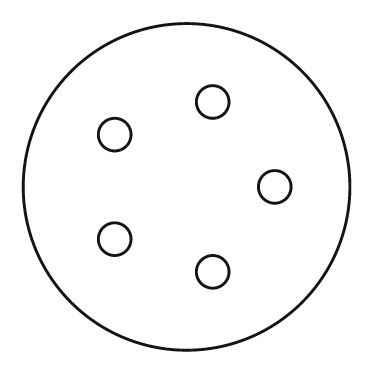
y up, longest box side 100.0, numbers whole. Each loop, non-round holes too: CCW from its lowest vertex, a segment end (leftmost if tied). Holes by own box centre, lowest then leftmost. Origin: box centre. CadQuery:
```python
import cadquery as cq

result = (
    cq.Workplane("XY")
    .moveTo(0.0, 0.0)
    .circle(50.0)
    .moveTo(8.0, -26.0)
    .circle(5.0)
    .moveTo(-22.0, -16.0)
    .circle(5.0)
    .moveTo(27.0, 0.0)
    .circle(5.0)
    .moveTo(-22.0, 16.0)
    .circle(5.0)
    .moveTo(8.0, 26.0)
    .circle(5.0)
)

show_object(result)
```